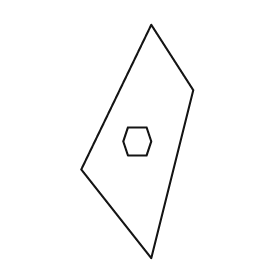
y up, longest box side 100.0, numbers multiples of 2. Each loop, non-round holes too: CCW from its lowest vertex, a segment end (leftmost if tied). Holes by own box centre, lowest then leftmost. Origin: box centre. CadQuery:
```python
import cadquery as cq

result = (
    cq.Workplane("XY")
    .moveTo(6.0, -50.0)
    .lineTo(24.0, 22.0)
    .lineTo(6.0, 50.0)
    .lineTo(-24.0, -12.0)
    .close()
    .moveTo(-4.0, -6.0)
    .lineTo(4.0, -6.0)
    .lineTo(6.0, 0.0)
    .lineTo(4.0, 6.0)
    .lineTo(-4.0, 6.0)
    .lineTo(-6.0, 0.0)
    .close()
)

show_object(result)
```